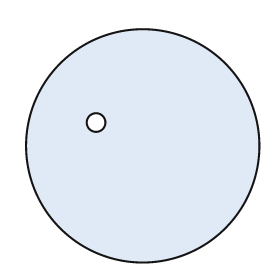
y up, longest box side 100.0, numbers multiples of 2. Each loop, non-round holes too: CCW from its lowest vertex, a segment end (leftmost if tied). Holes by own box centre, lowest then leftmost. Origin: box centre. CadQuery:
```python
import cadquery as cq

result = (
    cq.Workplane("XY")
    .moveTo(0.0, 0.0)
    .circle(50.0)
    .moveTo(-20.0, 10.0)
    .circle(4.0)
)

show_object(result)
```